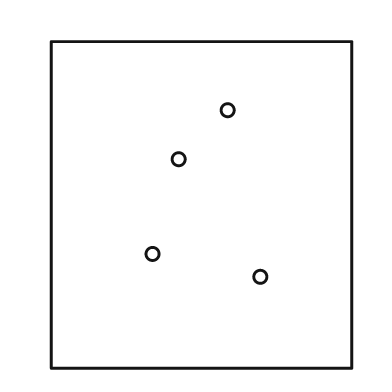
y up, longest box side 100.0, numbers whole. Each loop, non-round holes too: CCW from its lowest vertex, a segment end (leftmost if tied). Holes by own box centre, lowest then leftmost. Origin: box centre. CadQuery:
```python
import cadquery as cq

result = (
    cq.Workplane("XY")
    .moveTo(-46.0, -50.0)
    .lineTo(46.0, -50.0)
    .lineTo(46.0, 50.0)
    .lineTo(-46.0, 50.0)
    .close()
    .moveTo(18.0, -22.0)
    .circle(2.0)
    .moveTo(-15.0, -15.0)
    .circle(2.0)
    .moveTo(-7.0, 14.0)
    .circle(2.0)
    .moveTo(8.0, 29.0)
    .circle(2.0)
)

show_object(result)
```